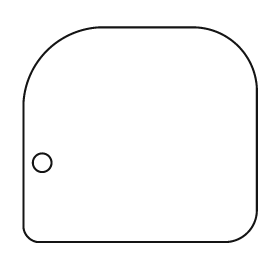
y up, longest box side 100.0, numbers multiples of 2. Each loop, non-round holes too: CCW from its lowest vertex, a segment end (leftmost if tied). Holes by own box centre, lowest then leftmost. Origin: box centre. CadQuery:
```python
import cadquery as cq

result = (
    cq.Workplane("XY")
    .moveTo(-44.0, -46.0)
    .lineTo(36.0, -46.0)
    .threePointArc((46.0, -42.0), (50.0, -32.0))
    .lineTo(50.0, 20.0)
    .threePointArc((42.0, 38.0), (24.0, 46.0))
    .lineTo(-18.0, 46.0)
    .threePointArc((-40.0, 36.0), (-50.0, 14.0))
    .lineTo(-50.0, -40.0)
    .threePointArc((-48.0, -44.0), (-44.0, -46.0))
    .close()
    .moveTo(-42.0, -12.0)
    .circle(4.0)
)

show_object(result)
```